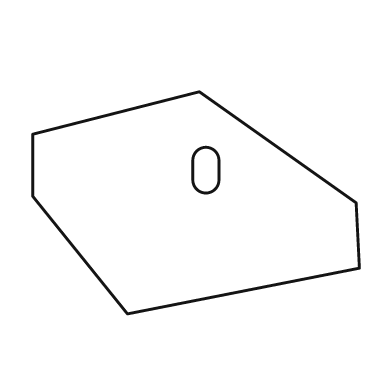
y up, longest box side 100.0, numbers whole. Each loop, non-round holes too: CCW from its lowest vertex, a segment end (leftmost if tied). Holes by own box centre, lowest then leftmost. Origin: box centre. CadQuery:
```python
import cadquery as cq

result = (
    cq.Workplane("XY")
    .moveTo(-21.0, -34.0)
    .lineTo(50.0, -20.0)
    .lineTo(49.0, 0.0)
    .lineTo(1.0, 34.0)
    .lineTo(-50.0, 21.0)
    .lineTo(-50.0, 2.0)
    .close()
    .moveTo(-1.0, 7.0)
    .threePointArc((3.0, 3.0), (7.0, 7.0))
    .lineTo(7.0, 13.0)
    .threePointArc((3.0, 17.0), (-1.0, 13.0))
    .close()
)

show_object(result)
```